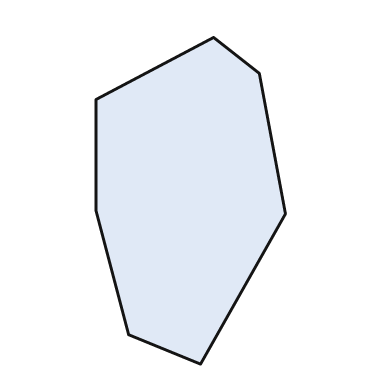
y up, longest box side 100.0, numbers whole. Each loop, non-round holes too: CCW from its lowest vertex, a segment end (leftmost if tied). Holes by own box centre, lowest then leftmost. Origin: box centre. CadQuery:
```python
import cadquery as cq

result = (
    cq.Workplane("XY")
    .moveTo(3.0, -50.0)
    .lineTo(29.0, -4.0)
    .lineTo(21.0, 39.0)
    .lineTo(7.0, 50.0)
    .lineTo(-29.0, 31.0)
    .lineTo(-29.0, -3.0)
    .lineTo(-19.0, -41.0)
    .close()
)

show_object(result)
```